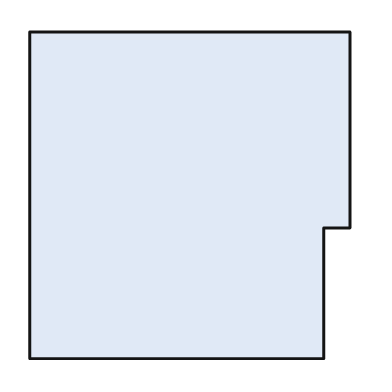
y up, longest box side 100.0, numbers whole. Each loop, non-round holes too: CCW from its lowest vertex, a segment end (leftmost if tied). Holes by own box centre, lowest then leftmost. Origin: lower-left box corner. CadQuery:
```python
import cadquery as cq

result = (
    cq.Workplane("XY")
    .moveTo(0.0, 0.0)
    .lineTo(90.0, 0.0)
    .lineTo(90.0, 40.0)
    .lineTo(98.0, 40.0)
    .lineTo(98.0, 100.0)
    .lineTo(0.0, 100.0)
    .close()
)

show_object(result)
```